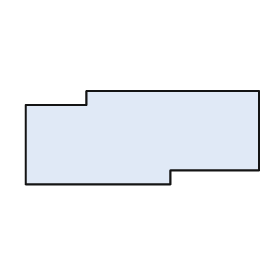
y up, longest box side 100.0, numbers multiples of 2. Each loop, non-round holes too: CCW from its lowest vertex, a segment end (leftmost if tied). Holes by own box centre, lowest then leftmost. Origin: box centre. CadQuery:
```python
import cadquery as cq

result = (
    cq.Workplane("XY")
    .moveTo(-50.0, -20.0)
    .lineTo(12.0, -20.0)
    .lineTo(12.0, -14.0)
    .lineTo(50.0, -14.0)
    .lineTo(50.0, 20.0)
    .lineTo(-24.0, 20.0)
    .lineTo(-24.0, 14.0)
    .lineTo(-50.0, 14.0)
    .close()
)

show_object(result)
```